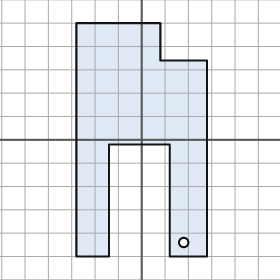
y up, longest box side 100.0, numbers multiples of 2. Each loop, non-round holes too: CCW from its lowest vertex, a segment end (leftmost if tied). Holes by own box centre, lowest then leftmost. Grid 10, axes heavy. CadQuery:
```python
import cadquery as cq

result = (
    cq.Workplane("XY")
    .moveTo(-28.0, -50.0)
    .lineTo(-14.0, -50.0)
    .lineTo(-14.0, -2.0)
    .lineTo(12.0, -2.0)
    .lineTo(12.0, -50.0)
    .lineTo(28.0, -50.0)
    .lineTo(28.0, 34.0)
    .lineTo(8.0, 34.0)
    .lineTo(8.0, 50.0)
    .lineTo(-28.0, 50.0)
    .close()
    .moveTo(18.0, -44.0)
    .circle(2.0)
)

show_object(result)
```